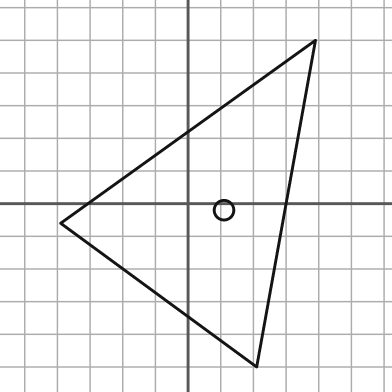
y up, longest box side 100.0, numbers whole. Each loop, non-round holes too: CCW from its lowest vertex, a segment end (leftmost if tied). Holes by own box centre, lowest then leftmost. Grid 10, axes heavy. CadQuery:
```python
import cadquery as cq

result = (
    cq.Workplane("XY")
    .moveTo(21.0, -50.0)
    .lineTo(39.0, 50.0)
    .lineTo(-39.0, -6.0)
    .close()
    .moveTo(11.0, -2.0)
    .circle(3.0)
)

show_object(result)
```